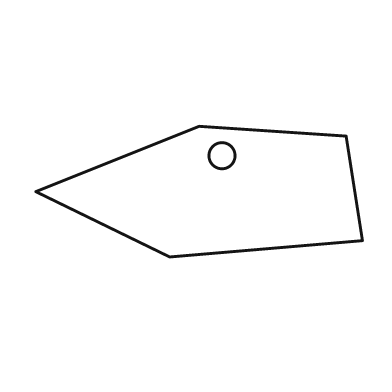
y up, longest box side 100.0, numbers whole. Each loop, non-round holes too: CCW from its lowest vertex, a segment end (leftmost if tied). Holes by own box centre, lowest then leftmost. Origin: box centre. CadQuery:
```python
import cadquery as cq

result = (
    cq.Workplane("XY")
    .moveTo(-9.0, -20.0)
    .lineTo(50.0, -15.0)
    .lineTo(45.0, 17.0)
    .lineTo(0.0, 20.0)
    .lineTo(-50.0, 0.0)
    .close()
    .moveTo(7.0, 11.0)
    .circle(4.0)
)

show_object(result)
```